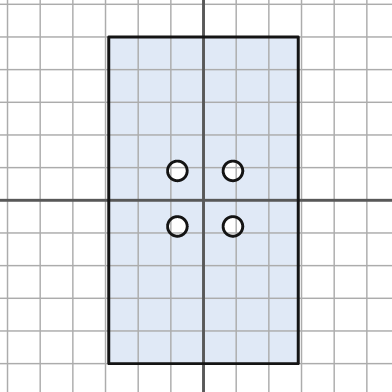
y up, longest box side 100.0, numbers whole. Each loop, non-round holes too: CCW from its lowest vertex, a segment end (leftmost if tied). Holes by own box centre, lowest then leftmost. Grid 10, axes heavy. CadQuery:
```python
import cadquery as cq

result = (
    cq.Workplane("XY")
    .moveTo(-29.0, -50.0)
    .lineTo(29.0, -50.0)
    .lineTo(29.0, 50.0)
    .lineTo(-29.0, 50.0)
    .close()
    .moveTo(-8.0, -8.0)
    .circle(3.0)
    .moveTo(9.0, -8.0)
    .circle(3.0)
    .moveTo(-8.0, 9.0)
    .circle(3.0)
    .moveTo(9.0, 9.0)
    .circle(3.0)
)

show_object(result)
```